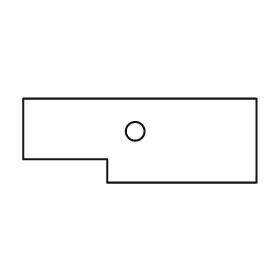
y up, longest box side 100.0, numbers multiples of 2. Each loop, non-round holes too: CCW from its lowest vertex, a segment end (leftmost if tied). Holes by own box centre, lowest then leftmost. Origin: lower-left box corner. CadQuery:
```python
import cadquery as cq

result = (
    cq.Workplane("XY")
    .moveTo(36.0, 0.0)
    .lineTo(100.0, 0.0)
    .lineTo(100.0, 36.0)
    .lineTo(0.0, 36.0)
    .lineTo(0.0, 10.0)
    .lineTo(36.0, 10.0)
    .close()
    .moveTo(48.0, 22.0)
    .circle(4.0)
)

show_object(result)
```